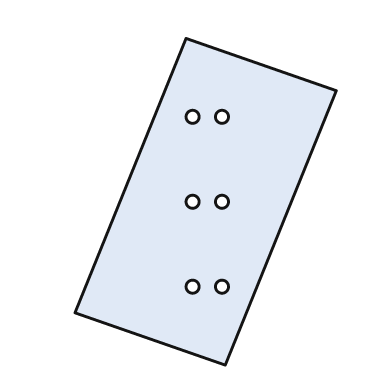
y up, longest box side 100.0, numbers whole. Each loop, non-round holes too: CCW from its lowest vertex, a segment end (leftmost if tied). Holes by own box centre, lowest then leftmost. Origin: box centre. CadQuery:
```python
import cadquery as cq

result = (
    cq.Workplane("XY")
    .moveTo(6.0, -50.0)
    .lineTo(40.0, 34.0)
    .lineTo(-6.0, 50.0)
    .lineTo(-40.0, -34.0)
    .close()
    .moveTo(-4.0, -26.0)
    .circle(2.0)
    .moveTo(5.0, -26.0)
    .circle(2.0)
    .moveTo(-4.0, 0.0)
    .circle(2.0)
    .moveTo(5.0, 0.0)
    .circle(2.0)
    .moveTo(-4.0, 26.0)
    .circle(2.0)
    .moveTo(5.0, 26.0)
    .circle(2.0)
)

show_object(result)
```